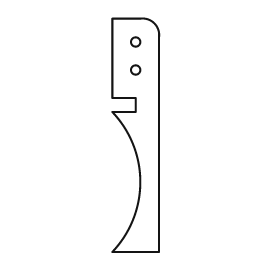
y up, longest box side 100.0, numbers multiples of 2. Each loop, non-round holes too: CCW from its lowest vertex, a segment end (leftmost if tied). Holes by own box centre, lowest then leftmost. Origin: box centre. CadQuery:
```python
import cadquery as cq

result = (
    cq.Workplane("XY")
    .moveTo(-10.0, -50.0)
    .lineTo(10.0, -50.0)
    .lineTo(10.0, 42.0)
    .threePointArc((8.0, 48.0), (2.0, 50.0))
    .lineTo(-10.0, 50.0)
    .lineTo(-10.0, 16.0)
    .lineTo(0.0, 16.0)
    .lineTo(0.0, 10.0)
    .lineTo(-10.0, 10.0)
    .threePointArc((2.0, -20.0), (-10.0, -50.0))
    .close()
    .moveTo(0.0, 28.0)
    .circle(2.0)
    .moveTo(0.0, 40.0)
    .circle(2.0)
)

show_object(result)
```